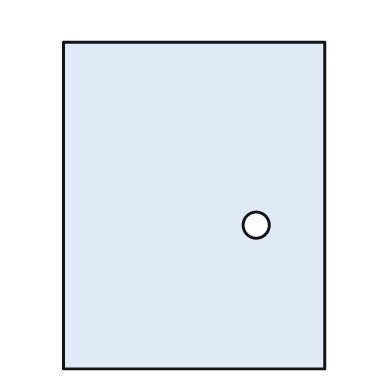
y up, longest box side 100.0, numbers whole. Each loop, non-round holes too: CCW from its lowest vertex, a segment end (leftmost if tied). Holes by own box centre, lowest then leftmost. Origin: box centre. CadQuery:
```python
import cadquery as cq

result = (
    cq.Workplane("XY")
    .moveTo(-40.0, -50.0)
    .lineTo(40.0, -50.0)
    .lineTo(40.0, 50.0)
    .lineTo(-40.0, 50.0)
    .close()
    .moveTo(19.0, -6.0)
    .circle(4.0)
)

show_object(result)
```